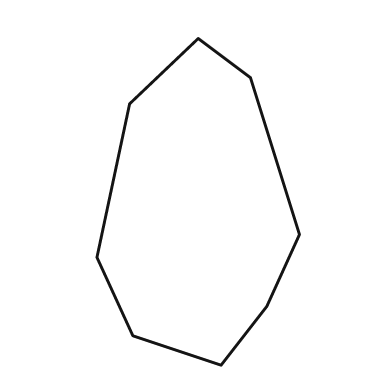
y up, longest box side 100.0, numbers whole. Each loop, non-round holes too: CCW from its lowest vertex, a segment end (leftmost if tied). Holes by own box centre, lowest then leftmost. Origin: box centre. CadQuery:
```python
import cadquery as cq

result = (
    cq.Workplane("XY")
    .moveTo(7.0, -50.0)
    .lineTo(21.0, -32.0)
    .lineTo(31.0, -10.0)
    .lineTo(16.0, 38.0)
    .lineTo(0.0, 50.0)
    .lineTo(-21.0, 30.0)
    .lineTo(-31.0, -17.0)
    .lineTo(-20.0, -41.0)
    .close()
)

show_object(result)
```